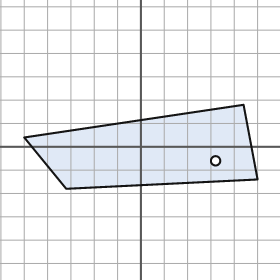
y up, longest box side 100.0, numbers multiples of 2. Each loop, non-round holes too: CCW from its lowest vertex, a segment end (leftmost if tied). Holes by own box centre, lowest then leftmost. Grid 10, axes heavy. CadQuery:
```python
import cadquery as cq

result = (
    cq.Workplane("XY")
    .moveTo(-32.0, -18.0)
    .lineTo(50.0, -14.0)
    .lineTo(44.0, 18.0)
    .lineTo(-50.0, 4.0)
    .close()
    .moveTo(32.0, -6.0)
    .circle(2.0)
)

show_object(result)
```